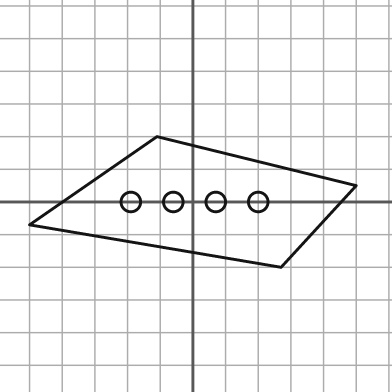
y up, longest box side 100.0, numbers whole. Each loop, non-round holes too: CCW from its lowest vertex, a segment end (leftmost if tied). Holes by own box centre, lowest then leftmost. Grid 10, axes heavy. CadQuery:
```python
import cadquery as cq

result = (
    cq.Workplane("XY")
    .moveTo(27.0, -20.0)
    .lineTo(50.0, 5.0)
    .lineTo(-11.0, 20.0)
    .lineTo(-50.0, -7.0)
    .close()
    .moveTo(-19.0, 0.0)
    .circle(3.0)
    .moveTo(-6.0, 0.0)
    .circle(3.0)
    .moveTo(7.0, 0.0)
    .circle(3.0)
    .moveTo(20.0, 0.0)
    .circle(3.0)
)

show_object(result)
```